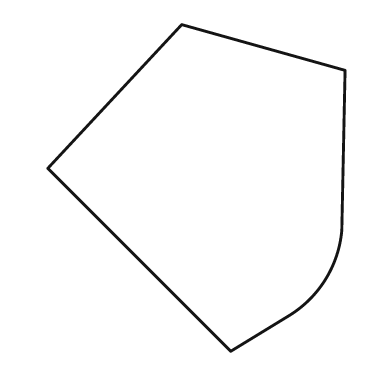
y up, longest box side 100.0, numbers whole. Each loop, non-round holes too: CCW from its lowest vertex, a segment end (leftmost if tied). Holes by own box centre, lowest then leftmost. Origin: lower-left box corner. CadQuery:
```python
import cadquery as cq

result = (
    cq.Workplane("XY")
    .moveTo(56.0, 0.0)
    .lineTo(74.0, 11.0)
    .threePointArc((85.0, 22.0), (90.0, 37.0))
    .lineTo(91.0, 86.0)
    .lineTo(41.0, 100.0)
    .lineTo(0.0, 56.0)
    .close()
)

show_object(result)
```